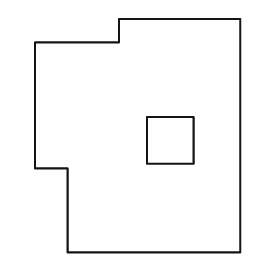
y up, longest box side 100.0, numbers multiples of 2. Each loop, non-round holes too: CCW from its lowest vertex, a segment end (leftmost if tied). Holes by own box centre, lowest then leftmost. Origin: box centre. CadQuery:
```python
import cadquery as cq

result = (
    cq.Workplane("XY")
    .moveTo(-30.0, -50.0)
    .lineTo(44.0, -50.0)
    .lineTo(44.0, 50.0)
    .lineTo(-8.0, 50.0)
    .lineTo(-8.0, 40.0)
    .lineTo(-44.0, 40.0)
    .lineTo(-44.0, -14.0)
    .lineTo(-30.0, -14.0)
    .close()
    .moveTo(4.0, -12.0)
    .lineTo(24.0, -12.0)
    .lineTo(24.0, 8.0)
    .lineTo(4.0, 8.0)
    .close()
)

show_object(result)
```